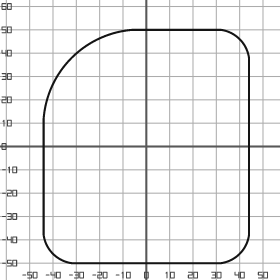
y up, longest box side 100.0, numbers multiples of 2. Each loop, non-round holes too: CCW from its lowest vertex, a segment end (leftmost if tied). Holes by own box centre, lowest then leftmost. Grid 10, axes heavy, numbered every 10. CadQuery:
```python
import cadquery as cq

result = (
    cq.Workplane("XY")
    .moveTo(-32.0, -50.0)
    .lineTo(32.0, -50.0)
    .threePointArc((40.0, -46.0), (44.0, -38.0))
    .lineTo(44.0, 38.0)
    .threePointArc((40.0, 46.0), (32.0, 50.0))
    .lineTo(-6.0, 50.0)
    .threePointArc((-32.0, 38.0), (-44.0, 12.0))
    .lineTo(-44.0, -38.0)
    .threePointArc((-40.0, -46.0), (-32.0, -50.0))
    .close()
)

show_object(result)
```